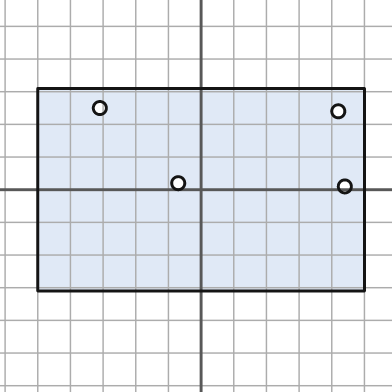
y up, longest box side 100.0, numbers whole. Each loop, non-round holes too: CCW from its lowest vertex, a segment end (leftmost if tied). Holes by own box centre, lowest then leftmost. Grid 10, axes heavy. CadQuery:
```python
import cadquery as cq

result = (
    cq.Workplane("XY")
    .moveTo(-50.0, -31.0)
    .lineTo(50.0, -31.0)
    .lineTo(50.0, 31.0)
    .lineTo(-50.0, 31.0)
    .close()
    .moveTo(44.0, 1.0)
    .circle(2.0)
    .moveTo(-7.0, 2.0)
    .circle(2.0)
    .moveTo(42.0, 24.0)
    .circle(2.0)
    .moveTo(-31.0, 25.0)
    .circle(2.0)
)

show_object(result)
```